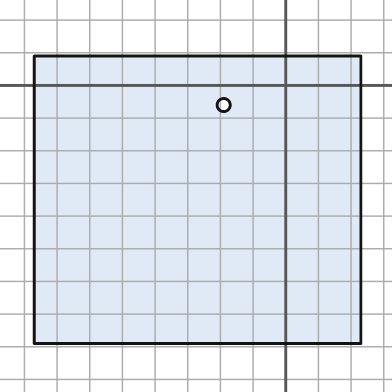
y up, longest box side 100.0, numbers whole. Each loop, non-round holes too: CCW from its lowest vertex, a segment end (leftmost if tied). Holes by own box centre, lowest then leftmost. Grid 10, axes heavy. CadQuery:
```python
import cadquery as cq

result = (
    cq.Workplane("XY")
    .moveTo(-77.0, -79.0)
    .lineTo(23.0, -79.0)
    .lineTo(23.0, 9.0)
    .lineTo(-77.0, 9.0)
    .close()
    .moveTo(-19.0, -6.0)
    .circle(2.0)
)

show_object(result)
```